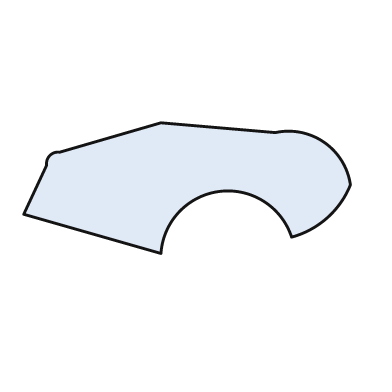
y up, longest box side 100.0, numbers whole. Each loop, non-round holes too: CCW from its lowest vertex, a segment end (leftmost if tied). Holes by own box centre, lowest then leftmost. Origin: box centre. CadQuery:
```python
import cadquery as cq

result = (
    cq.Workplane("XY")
    .moveTo(-8.0, -20.0)
    .threePointArc((10.0, -1.0), (32.0, -15.0))
    .threePointArc((43.0, -9.0), (50.0, 1.0))
    .threePointArc((42.0, 14.0), (27.0, 17.0))
    .lineTo(-8.0, 20.0)
    .lineTo(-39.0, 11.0)
    .threePointArc((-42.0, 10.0), (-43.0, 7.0))
    .lineTo(-50.0, -8.0)
    .close()
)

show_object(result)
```